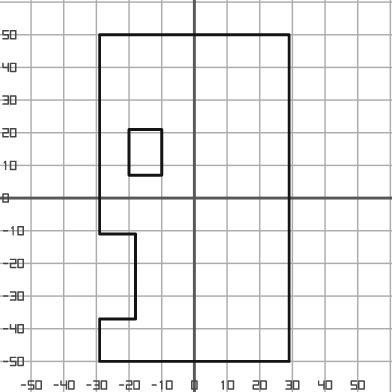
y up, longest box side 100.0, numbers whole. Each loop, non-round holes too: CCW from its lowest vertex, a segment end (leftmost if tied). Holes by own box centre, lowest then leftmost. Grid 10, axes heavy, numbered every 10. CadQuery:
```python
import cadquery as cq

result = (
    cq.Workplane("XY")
    .moveTo(-29.0, -50.0)
    .lineTo(29.0, -50.0)
    .lineTo(29.0, 50.0)
    .lineTo(-29.0, 50.0)
    .lineTo(-29.0, -11.0)
    .lineTo(-18.0, -11.0)
    .lineTo(-18.0, -37.0)
    .lineTo(-29.0, -37.0)
    .close()
    .moveTo(-20.0, 7.0)
    .lineTo(-10.0, 7.0)
    .lineTo(-10.0, 21.0)
    .lineTo(-20.0, 21.0)
    .close()
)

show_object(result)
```